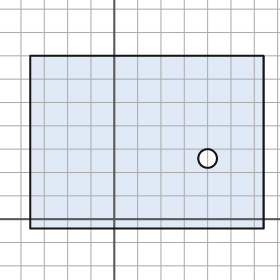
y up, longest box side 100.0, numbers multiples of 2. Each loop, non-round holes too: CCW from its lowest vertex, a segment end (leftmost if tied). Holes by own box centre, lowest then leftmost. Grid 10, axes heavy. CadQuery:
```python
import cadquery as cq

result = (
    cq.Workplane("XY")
    .moveTo(-36.0, -4.0)
    .lineTo(64.0, -4.0)
    .lineTo(64.0, 70.0)
    .lineTo(-36.0, 70.0)
    .close()
    .moveTo(40.0, 26.0)
    .circle(4.0)
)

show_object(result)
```